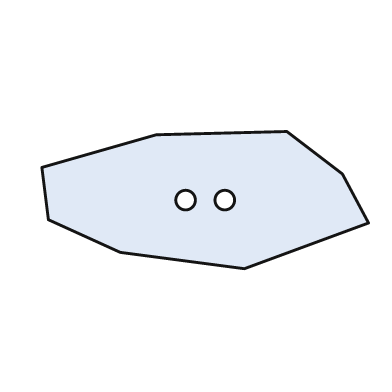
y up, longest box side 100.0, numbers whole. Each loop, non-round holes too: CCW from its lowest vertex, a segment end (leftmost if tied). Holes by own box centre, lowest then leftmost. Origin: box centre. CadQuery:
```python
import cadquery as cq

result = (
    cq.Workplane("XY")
    .moveTo(12.0, -21.0)
    .lineTo(50.0, -7.0)
    .lineTo(42.0, 8.0)
    .lineTo(25.0, 21.0)
    .lineTo(-15.0, 20.0)
    .lineTo(-50.0, 10.0)
    .lineTo(-48.0, -6.0)
    .lineTo(-26.0, -16.0)
    .close()
    .moveTo(-6.0, 0.0)
    .circle(3.0)
    .moveTo(6.0, 0.0)
    .circle(3.0)
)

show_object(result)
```